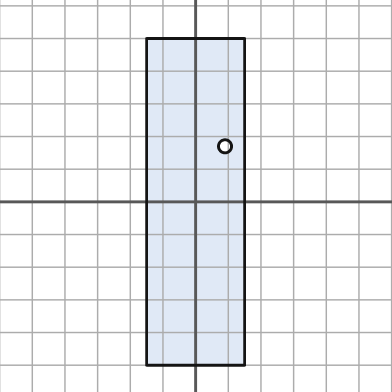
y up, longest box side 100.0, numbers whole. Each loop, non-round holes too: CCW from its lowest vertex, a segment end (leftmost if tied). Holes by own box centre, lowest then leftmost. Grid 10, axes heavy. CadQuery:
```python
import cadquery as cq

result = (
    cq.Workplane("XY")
    .moveTo(-15.0, -50.0)
    .lineTo(15.0, -50.0)
    .lineTo(15.0, 50.0)
    .lineTo(-15.0, 50.0)
    .close()
    .moveTo(9.0, 17.0)
    .circle(2.0)
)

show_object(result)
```